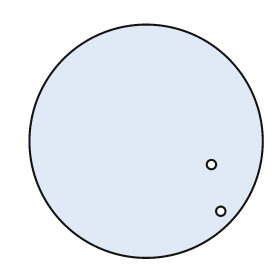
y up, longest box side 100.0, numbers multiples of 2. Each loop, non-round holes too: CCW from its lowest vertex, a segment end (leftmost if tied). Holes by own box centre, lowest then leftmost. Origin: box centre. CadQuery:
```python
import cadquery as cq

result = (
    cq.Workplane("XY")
    .moveTo(0.0, 0.0)
    .circle(50.0)
    .moveTo(32.0, -30.0)
    .circle(2.0)
    .moveTo(28.0, -10.0)
    .circle(2.0)
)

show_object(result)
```